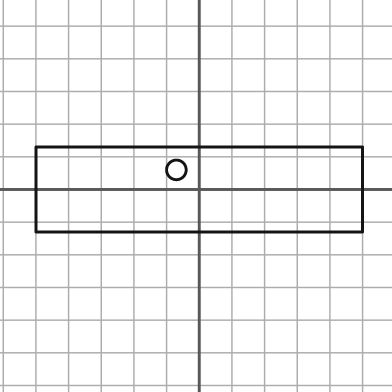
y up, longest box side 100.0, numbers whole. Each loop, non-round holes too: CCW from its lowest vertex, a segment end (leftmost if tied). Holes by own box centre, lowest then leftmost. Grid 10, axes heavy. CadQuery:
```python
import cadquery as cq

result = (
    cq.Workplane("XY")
    .moveTo(-50.0, -13.0)
    .lineTo(50.0, -13.0)
    .lineTo(50.0, 13.0)
    .lineTo(-50.0, 13.0)
    .close()
    .moveTo(-7.0, 6.0)
    .circle(3.0)
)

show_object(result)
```